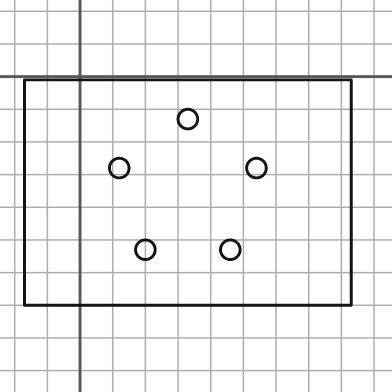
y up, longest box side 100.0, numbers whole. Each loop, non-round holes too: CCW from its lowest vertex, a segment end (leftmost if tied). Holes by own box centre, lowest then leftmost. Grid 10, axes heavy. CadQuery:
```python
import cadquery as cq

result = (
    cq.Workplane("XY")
    .moveTo(-17.0, -70.0)
    .lineTo(83.0, -70.0)
    .lineTo(83.0, -1.0)
    .lineTo(-17.0, -1.0)
    .close()
    .moveTo(20.0, -53.0)
    .circle(3.0)
    .moveTo(46.0, -53.0)
    .circle(3.0)
    .moveTo(12.0, -28.0)
    .circle(3.0)
    .moveTo(54.0, -28.0)
    .circle(3.0)
    .moveTo(33.0, -13.0)
    .circle(3.0)
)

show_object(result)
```